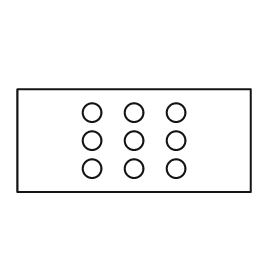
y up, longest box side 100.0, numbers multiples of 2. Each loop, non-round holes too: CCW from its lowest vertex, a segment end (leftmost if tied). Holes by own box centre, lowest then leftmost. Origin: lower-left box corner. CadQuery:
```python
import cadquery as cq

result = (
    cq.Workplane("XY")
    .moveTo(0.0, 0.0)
    .lineTo(100.0, 0.0)
    .lineTo(100.0, 44.0)
    .lineTo(0.0, 44.0)
    .close()
    .moveTo(32.0, 10.0)
    .circle(4.0)
    .moveTo(50.0, 10.0)
    .circle(4.0)
    .moveTo(68.0, 10.0)
    .circle(4.0)
    .moveTo(32.0, 22.0)
    .circle(4.0)
    .moveTo(50.0, 22.0)
    .circle(4.0)
    .moveTo(68.0, 22.0)
    .circle(4.0)
    .moveTo(32.0, 34.0)
    .circle(4.0)
    .moveTo(50.0, 34.0)
    .circle(4.0)
    .moveTo(68.0, 34.0)
    .circle(4.0)
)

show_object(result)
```